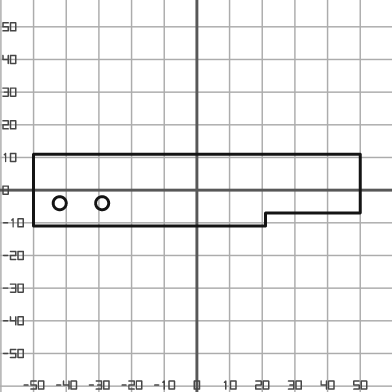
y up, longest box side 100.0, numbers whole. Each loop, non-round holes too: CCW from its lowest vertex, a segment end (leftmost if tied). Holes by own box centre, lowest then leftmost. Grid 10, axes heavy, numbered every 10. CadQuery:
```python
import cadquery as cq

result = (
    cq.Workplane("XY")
    .moveTo(-50.0, -11.0)
    .lineTo(21.0, -11.0)
    .lineTo(21.0, -7.0)
    .lineTo(50.0, -7.0)
    .lineTo(50.0, 11.0)
    .lineTo(-50.0, 11.0)
    .close()
    .moveTo(-42.0, -4.0)
    .circle(2.0)
    .moveTo(-29.0, -4.0)
    .circle(2.0)
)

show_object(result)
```